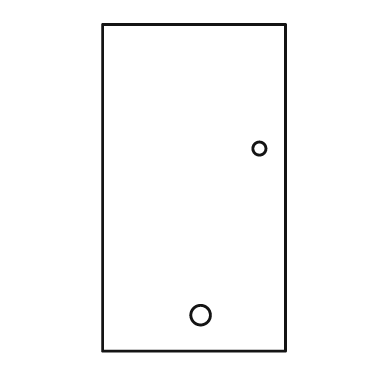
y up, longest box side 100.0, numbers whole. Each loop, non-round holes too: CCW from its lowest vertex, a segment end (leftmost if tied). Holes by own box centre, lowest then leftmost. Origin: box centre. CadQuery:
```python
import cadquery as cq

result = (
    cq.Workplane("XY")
    .moveTo(-28.0, -50.0)
    .lineTo(28.0, -50.0)
    .lineTo(28.0, 50.0)
    .lineTo(-28.0, 50.0)
    .close()
    .moveTo(2.0, -39.0)
    .circle(3.0)
    .moveTo(20.0, 12.0)
    .circle(2.0)
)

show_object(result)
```